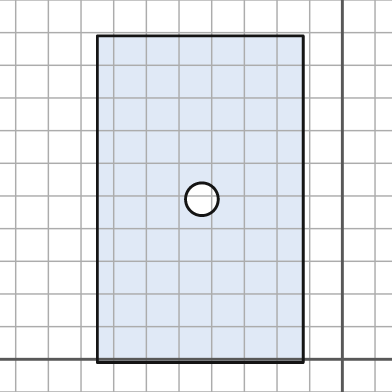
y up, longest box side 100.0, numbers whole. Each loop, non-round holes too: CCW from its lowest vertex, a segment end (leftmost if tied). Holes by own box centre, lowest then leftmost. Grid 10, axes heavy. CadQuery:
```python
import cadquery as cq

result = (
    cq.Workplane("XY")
    .moveTo(-75.0, -1.0)
    .lineTo(-12.0, -1.0)
    .lineTo(-12.0, 99.0)
    .lineTo(-75.0, 99.0)
    .close()
    .moveTo(-43.0, 49.0)
    .circle(5.0)
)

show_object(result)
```